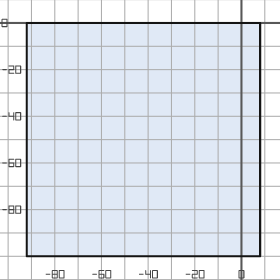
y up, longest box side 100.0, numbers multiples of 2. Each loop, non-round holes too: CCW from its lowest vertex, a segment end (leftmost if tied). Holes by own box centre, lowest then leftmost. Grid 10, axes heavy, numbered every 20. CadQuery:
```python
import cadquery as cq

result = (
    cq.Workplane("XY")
    .moveTo(-92.0, -100.0)
    .lineTo(8.0, -100.0)
    .lineTo(8.0, 0.0)
    .lineTo(-92.0, 0.0)
    .close()
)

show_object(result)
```